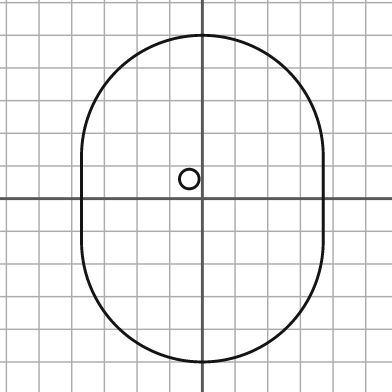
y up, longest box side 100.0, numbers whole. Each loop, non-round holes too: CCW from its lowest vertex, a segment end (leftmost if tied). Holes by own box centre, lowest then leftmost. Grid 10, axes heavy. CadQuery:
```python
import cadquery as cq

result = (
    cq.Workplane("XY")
    .moveTo(-37.0, -13.0)
    .threePointArc((0.0, -50.0), (37.0, -13.0))
    .lineTo(37.0, 13.0)
    .threePointArc((0.0, 50.0), (-37.0, 13.0))
    .close()
    .moveTo(-4.0, 6.0)
    .circle(3.0)
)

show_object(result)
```